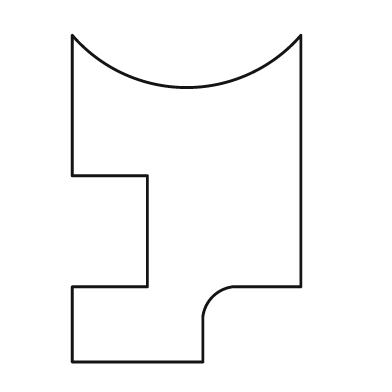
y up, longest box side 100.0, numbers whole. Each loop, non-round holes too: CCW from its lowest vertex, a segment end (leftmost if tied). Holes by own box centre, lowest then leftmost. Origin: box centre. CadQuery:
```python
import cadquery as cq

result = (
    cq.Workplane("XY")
    .moveTo(-35.0, -50.0)
    .lineTo(5.0, -50.0)
    .lineTo(5.0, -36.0)
    .threePointArc((8.0, -30.0), (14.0, -27.0))
    .lineTo(35.0, -27.0)
    .lineTo(35.0, 50.0)
    .threePointArc((0.0, 34.0), (-35.0, 50.0))
    .lineTo(-35.0, 7.0)
    .lineTo(-12.0, 7.0)
    .lineTo(-12.0, -27.0)
    .lineTo(-35.0, -27.0)
    .close()
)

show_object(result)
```